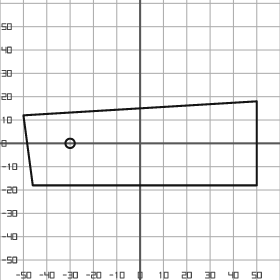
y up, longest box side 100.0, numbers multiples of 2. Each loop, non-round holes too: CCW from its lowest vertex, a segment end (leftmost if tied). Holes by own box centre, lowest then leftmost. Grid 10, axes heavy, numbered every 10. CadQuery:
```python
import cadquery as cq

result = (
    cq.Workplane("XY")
    .moveTo(-46.0, -18.0)
    .lineTo(50.0, -18.0)
    .lineTo(50.0, 18.0)
    .lineTo(-50.0, 12.0)
    .close()
    .moveTo(-30.0, 0.0)
    .circle(2.0)
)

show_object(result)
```